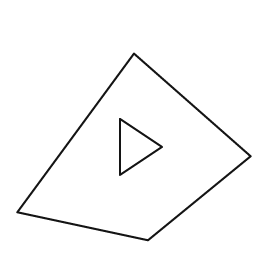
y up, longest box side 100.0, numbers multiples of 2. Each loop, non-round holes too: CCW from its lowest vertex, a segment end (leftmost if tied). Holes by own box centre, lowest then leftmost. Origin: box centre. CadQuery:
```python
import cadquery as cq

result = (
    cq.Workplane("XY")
    .moveTo(6.0, -40.0)
    .lineTo(50.0, -4.0)
    .lineTo(0.0, 40.0)
    .lineTo(-50.0, -28.0)
    .close()
    .moveTo(-6.0, -12.0)
    .lineTo(12.0, 0.0)
    .lineTo(-6.0, 12.0)
    .close()
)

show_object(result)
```